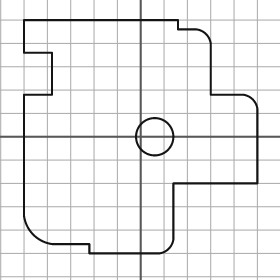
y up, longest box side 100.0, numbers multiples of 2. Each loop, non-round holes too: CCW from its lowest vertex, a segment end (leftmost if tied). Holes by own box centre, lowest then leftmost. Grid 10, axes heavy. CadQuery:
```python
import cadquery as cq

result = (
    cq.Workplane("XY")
    .moveTo(-22.0, -50.0)
    .lineTo(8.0, -50.0)
    .threePointArc((12.0, -48.0), (14.0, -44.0))
    .lineTo(14.0, -20.0)
    .lineTo(50.0, -20.0)
    .lineTo(50.0, 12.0)
    .threePointArc((48.0, 16.0), (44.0, 18.0))
    .lineTo(30.0, 18.0)
    .lineTo(30.0, 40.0)
    .threePointArc((28.0, 44.0), (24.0, 46.0))
    .lineTo(16.0, 46.0)
    .lineTo(16.0, 50.0)
    .lineTo(-50.0, 50.0)
    .lineTo(-50.0, 36.0)
    .lineTo(-38.0, 36.0)
    .lineTo(-38.0, 18.0)
    .lineTo(-50.0, 18.0)
    .lineTo(-50.0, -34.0)
    .threePointArc((-46.0, -42.0), (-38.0, -46.0))
    .lineTo(-22.0, -46.0)
    .close()
    .moveTo(6.0, 0.0)
    .circle(8.0)
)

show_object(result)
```